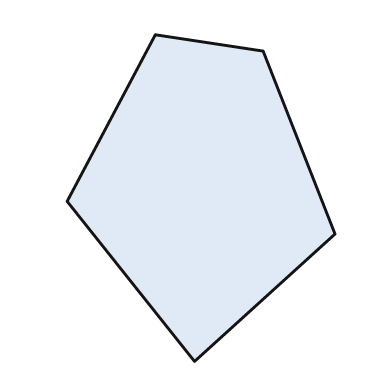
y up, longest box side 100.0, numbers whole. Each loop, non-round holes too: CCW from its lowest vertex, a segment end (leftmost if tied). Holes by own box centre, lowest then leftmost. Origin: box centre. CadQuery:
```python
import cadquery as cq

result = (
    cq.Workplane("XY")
    .moveTo(-2.0, -50.0)
    .lineTo(41.0, -11.0)
    .lineTo(19.0, 45.0)
    .lineTo(-14.0, 50.0)
    .lineTo(-41.0, -1.0)
    .close()
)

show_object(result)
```